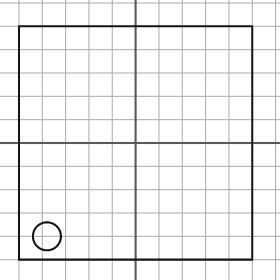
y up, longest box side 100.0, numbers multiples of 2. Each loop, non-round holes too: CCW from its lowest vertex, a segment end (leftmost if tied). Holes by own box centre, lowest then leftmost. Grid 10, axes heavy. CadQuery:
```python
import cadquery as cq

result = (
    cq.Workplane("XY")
    .moveTo(-50.0, -50.0)
    .lineTo(50.0, -50.0)
    .lineTo(50.0, 50.0)
    .lineTo(-50.0, 50.0)
    .close()
    .moveTo(-38.0, -40.0)
    .circle(6.0)
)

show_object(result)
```